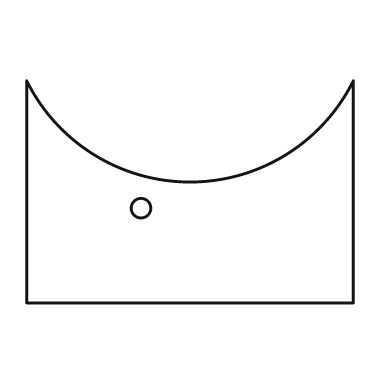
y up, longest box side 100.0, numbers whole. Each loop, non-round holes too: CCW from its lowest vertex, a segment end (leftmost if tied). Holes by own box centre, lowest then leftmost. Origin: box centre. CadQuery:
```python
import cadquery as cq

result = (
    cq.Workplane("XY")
    .moveTo(-50.0, -34.0)
    .lineTo(50.0, -34.0)
    .lineTo(50.0, 34.0)
    .threePointArc((0.0, 3.0), (-50.0, 34.0))
    .close()
    .moveTo(-15.0, -5.0)
    .circle(3.0)
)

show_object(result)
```